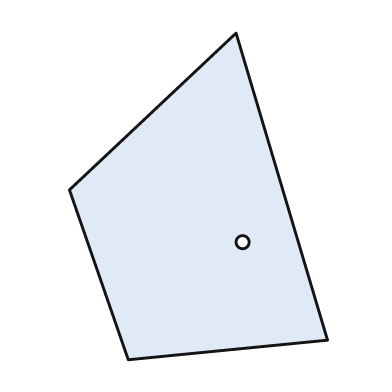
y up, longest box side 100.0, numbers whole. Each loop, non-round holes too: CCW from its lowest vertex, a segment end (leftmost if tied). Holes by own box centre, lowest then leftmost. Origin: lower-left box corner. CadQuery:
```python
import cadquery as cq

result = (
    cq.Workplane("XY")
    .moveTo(18.0, 0.0)
    .lineTo(79.0, 6.0)
    .lineTo(51.0, 100.0)
    .lineTo(0.0, 52.0)
    .close()
    .moveTo(53.0, 36.0)
    .circle(2.0)
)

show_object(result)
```